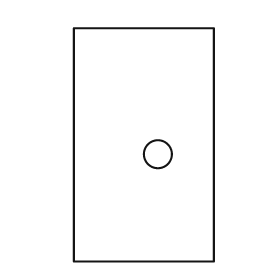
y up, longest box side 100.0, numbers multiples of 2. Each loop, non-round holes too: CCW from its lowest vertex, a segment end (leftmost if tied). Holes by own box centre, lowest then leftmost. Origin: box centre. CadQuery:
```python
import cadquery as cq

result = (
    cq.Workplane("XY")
    .moveTo(-30.0, -50.0)
    .lineTo(30.0, -50.0)
    .lineTo(30.0, 50.0)
    .lineTo(-30.0, 50.0)
    .close()
    .moveTo(6.0, -4.0)
    .circle(6.0)
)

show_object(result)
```